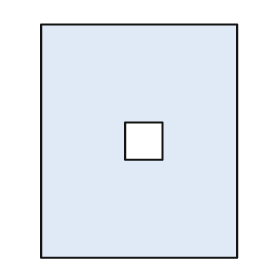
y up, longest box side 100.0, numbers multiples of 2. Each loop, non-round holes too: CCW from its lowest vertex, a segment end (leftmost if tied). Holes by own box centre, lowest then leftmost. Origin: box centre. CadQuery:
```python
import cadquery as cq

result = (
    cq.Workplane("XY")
    .moveTo(-42.0, -50.0)
    .lineTo(42.0, -50.0)
    .lineTo(42.0, 50.0)
    .lineTo(-42.0, 50.0)
    .close()
    .moveTo(-6.0, -8.0)
    .lineTo(10.0, -8.0)
    .lineTo(10.0, 8.0)
    .lineTo(-6.0, 8.0)
    .close()
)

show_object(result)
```